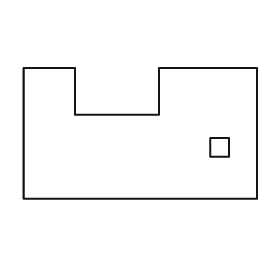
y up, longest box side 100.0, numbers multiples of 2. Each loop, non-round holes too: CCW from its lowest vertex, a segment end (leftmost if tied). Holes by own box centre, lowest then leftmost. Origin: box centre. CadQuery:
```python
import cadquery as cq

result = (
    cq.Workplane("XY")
    .moveTo(-50.0, -28.0)
    .lineTo(50.0, -28.0)
    .lineTo(50.0, 28.0)
    .lineTo(8.0, 28.0)
    .lineTo(8.0, 8.0)
    .lineTo(-28.0, 8.0)
    .lineTo(-28.0, 28.0)
    .lineTo(-50.0, 28.0)
    .close()
    .moveTo(30.0, -10.0)
    .lineTo(38.0, -10.0)
    .lineTo(38.0, -2.0)
    .lineTo(30.0, -2.0)
    .close()
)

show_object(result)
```